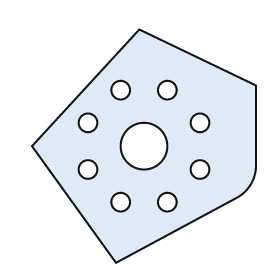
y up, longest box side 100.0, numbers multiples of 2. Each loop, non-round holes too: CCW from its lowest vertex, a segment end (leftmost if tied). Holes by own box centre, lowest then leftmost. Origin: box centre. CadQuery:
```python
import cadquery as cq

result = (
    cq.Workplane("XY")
    .moveTo(-12.0, -50.0)
    .lineTo(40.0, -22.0)
    .threePointArc((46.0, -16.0), (48.0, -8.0))
    .lineTo(48.0, 26.0)
    .lineTo(-2.0, 50.0)
    .lineTo(-48.0, 0.0)
    .close()
    .moveTo(-10.0, -24.0)
    .circle(4.0)
    .moveTo(10.0, -24.0)
    .circle(4.0)
    .moveTo(-24.0, -10.0)
    .circle(4.0)
    .moveTo(24.0, -10.0)
    .circle(4.0)
    .moveTo(0.0, 0.0)
    .circle(10.0)
    .moveTo(-24.0, 10.0)
    .circle(4.0)
    .moveTo(24.0, 10.0)
    .circle(4.0)
    .moveTo(-10.0, 24.0)
    .circle(4.0)
    .moveTo(10.0, 24.0)
    .circle(4.0)
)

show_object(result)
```